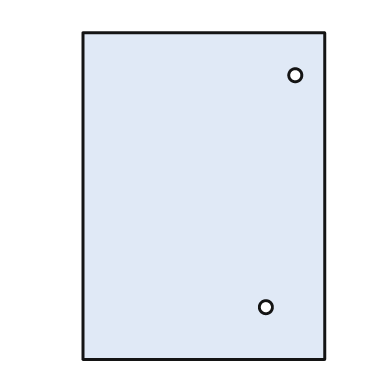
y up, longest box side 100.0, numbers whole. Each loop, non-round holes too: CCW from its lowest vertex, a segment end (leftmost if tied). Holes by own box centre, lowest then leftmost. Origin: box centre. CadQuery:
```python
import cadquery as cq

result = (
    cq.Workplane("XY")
    .moveTo(-37.0, -50.0)
    .lineTo(37.0, -50.0)
    .lineTo(37.0, 50.0)
    .lineTo(-37.0, 50.0)
    .close()
    .moveTo(19.0, -34.0)
    .circle(2.0)
    .moveTo(28.0, 37.0)
    .circle(2.0)
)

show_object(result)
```